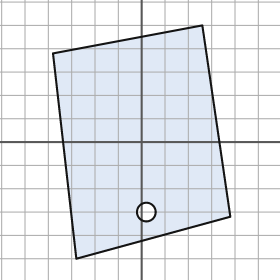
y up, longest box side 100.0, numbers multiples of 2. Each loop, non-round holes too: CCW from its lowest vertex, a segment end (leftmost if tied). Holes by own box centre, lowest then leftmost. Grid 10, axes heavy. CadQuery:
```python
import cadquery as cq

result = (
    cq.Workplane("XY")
    .moveTo(-28.0, -50.0)
    .lineTo(38.0, -32.0)
    .lineTo(26.0, 50.0)
    .lineTo(-38.0, 38.0)
    .close()
    .moveTo(2.0, -30.0)
    .circle(4.0)
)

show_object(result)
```